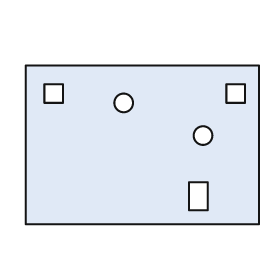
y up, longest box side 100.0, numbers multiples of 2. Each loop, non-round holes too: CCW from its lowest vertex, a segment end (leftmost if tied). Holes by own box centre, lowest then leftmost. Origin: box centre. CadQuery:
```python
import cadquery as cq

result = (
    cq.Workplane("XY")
    .moveTo(-50.0, -34.0)
    .lineTo(50.0, -34.0)
    .lineTo(50.0, 34.0)
    .lineTo(-50.0, 34.0)
    .close()
    .moveTo(20.0, -28.0)
    .lineTo(28.0, -28.0)
    .lineTo(28.0, -16.0)
    .lineTo(20.0, -16.0)
    .close()
    .moveTo(26.0, 4.0)
    .circle(4.0)
    .moveTo(-8.0, 18.0)
    .circle(4.0)
    .moveTo(-42.0, 18.0)
    .lineTo(-34.0, 18.0)
    .lineTo(-34.0, 26.0)
    .lineTo(-42.0, 26.0)
    .close()
    .moveTo(36.0, 18.0)
    .lineTo(44.0, 18.0)
    .lineTo(44.0, 26.0)
    .lineTo(36.0, 26.0)
    .close()
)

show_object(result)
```